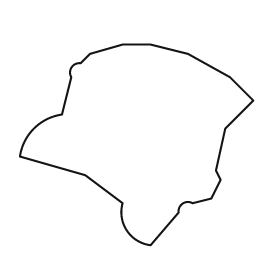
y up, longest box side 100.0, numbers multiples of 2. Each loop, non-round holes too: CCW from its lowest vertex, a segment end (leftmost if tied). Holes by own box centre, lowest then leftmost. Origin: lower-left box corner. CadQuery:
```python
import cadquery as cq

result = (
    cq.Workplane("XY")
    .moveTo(56.0, 0.0)
    .lineTo(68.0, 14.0)
    .threePointArc((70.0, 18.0), (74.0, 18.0))
    .lineTo(82.0, 20.0)
    .lineTo(86.0, 28.0)
    .lineTo(84.0, 32.0)
    .lineTo(88.0, 50.0)
    .lineTo(100.0, 62.0)
    .lineTo(90.0, 72.0)
    .lineTo(72.0, 82.0)
    .lineTo(56.0, 86.0)
    .lineTo(44.0, 86.0)
    .lineTo(30.0, 82.0)
    .lineTo(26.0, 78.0)
    .threePointArc((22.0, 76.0), (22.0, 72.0))
    .lineTo(18.0, 56.0)
    .threePointArc((6.0, 50.0), (0.0, 38.0))
    .lineTo(28.0, 30.0)
    .lineTo(44.0, 18.0)
    .threePointArc((46.0, 6.0), (56.0, 0.0))
    .close()
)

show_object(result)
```